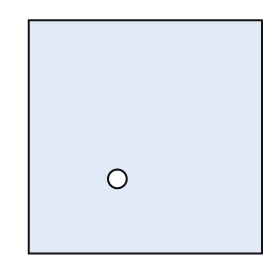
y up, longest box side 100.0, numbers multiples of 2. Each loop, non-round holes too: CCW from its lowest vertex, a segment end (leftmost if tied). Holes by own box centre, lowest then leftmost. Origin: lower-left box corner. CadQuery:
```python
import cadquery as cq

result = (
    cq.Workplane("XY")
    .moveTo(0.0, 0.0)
    .lineTo(100.0, 0.0)
    .lineTo(100.0, 100.0)
    .lineTo(0.0, 100.0)
    .close()
    .moveTo(38.0, 32.0)
    .circle(4.0)
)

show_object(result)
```